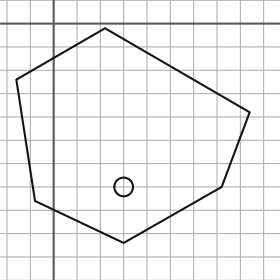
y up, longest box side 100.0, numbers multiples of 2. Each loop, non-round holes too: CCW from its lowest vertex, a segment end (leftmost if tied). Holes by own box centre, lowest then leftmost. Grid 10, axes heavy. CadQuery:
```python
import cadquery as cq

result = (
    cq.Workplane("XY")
    .moveTo(30.0, -94.0)
    .lineTo(72.0, -70.0)
    .lineTo(84.0, -38.0)
    .lineTo(22.0, -2.0)
    .lineTo(-16.0, -24.0)
    .lineTo(-8.0, -76.0)
    .close()
    .moveTo(30.0, -70.0)
    .circle(4.0)
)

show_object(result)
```